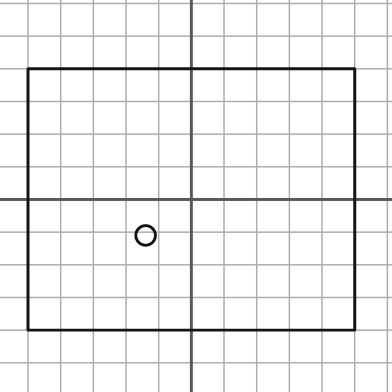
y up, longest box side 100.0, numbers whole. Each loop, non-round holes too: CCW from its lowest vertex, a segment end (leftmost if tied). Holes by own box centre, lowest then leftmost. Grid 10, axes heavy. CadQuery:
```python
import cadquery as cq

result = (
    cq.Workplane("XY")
    .moveTo(-50.0, -40.0)
    .lineTo(50.0, -40.0)
    .lineTo(50.0, 40.0)
    .lineTo(-50.0, 40.0)
    .close()
    .moveTo(-14.0, -11.0)
    .circle(3.0)
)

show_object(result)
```